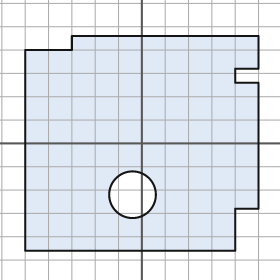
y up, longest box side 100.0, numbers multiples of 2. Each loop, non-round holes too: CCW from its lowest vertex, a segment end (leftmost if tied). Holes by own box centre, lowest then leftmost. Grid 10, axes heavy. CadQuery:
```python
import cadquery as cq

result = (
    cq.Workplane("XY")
    .moveTo(-50.0, -46.0)
    .lineTo(40.0, -46.0)
    .lineTo(40.0, -28.0)
    .lineTo(50.0, -28.0)
    .lineTo(50.0, 26.0)
    .lineTo(40.0, 26.0)
    .lineTo(40.0, 32.0)
    .lineTo(50.0, 32.0)
    .lineTo(50.0, 46.0)
    .lineTo(-30.0, 46.0)
    .lineTo(-30.0, 40.0)
    .lineTo(-50.0, 40.0)
    .close()
    .moveTo(-4.0, -22.0)
    .circle(10.0)
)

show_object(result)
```